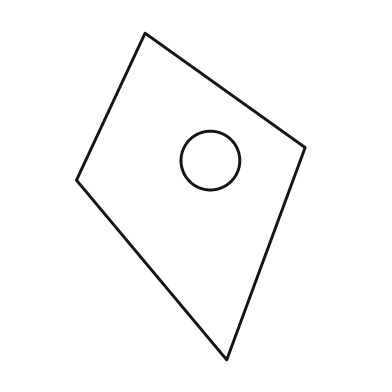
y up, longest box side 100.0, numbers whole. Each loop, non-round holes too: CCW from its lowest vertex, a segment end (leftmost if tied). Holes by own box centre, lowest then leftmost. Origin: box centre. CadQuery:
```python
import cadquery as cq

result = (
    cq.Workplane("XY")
    .moveTo(11.0, -50.0)
    .lineTo(35.0, 15.0)
    .lineTo(-14.0, 50.0)
    .lineTo(-35.0, 5.0)
    .close()
    .moveTo(6.0, 11.0)
    .circle(9.0)
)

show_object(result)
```